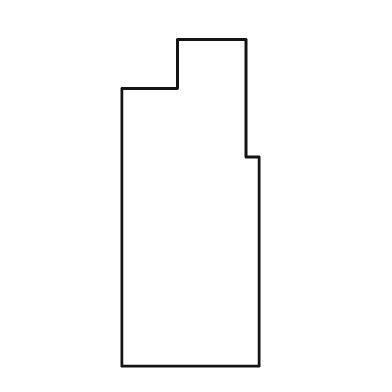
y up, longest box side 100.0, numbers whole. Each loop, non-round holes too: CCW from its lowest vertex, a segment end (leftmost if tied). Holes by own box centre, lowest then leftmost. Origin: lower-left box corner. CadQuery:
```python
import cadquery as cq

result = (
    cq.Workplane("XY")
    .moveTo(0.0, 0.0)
    .lineTo(42.0, 0.0)
    .lineTo(42.0, 64.0)
    .lineTo(38.0, 64.0)
    .lineTo(38.0, 100.0)
    .lineTo(17.0, 100.0)
    .lineTo(17.0, 85.0)
    .lineTo(0.0, 85.0)
    .close()
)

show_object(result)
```